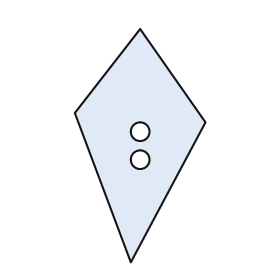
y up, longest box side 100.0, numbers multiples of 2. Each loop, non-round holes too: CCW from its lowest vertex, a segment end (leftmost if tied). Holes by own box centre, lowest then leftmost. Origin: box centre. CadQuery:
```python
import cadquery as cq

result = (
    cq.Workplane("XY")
    .moveTo(-4.0, -50.0)
    .lineTo(28.0, 10.0)
    .lineTo(0.0, 50.0)
    .lineTo(-28.0, 14.0)
    .close()
    .moveTo(0.0, -6.0)
    .circle(4.0)
    .moveTo(0.0, 6.0)
    .circle(4.0)
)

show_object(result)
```